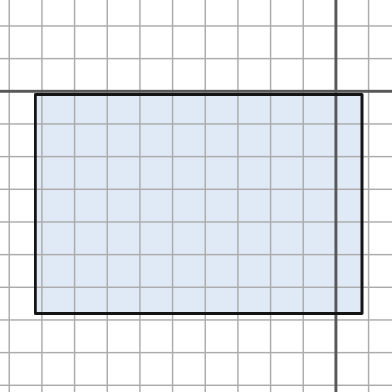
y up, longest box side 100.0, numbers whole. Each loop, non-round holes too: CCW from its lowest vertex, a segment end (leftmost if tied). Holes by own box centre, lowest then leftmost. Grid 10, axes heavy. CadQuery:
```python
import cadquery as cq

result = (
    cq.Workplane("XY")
    .moveTo(-92.0, -68.0)
    .lineTo(8.0, -68.0)
    .lineTo(8.0, -1.0)
    .lineTo(-92.0, -1.0)
    .close()
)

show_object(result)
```